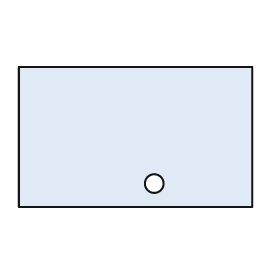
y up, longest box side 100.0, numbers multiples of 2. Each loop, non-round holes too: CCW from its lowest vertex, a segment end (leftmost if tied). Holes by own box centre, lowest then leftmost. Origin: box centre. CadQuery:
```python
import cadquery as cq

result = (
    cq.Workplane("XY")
    .moveTo(-50.0, -30.0)
    .lineTo(50.0, -30.0)
    .lineTo(50.0, 30.0)
    .lineTo(-50.0, 30.0)
    .close()
    .moveTo(8.0, -20.0)
    .circle(4.0)
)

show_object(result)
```